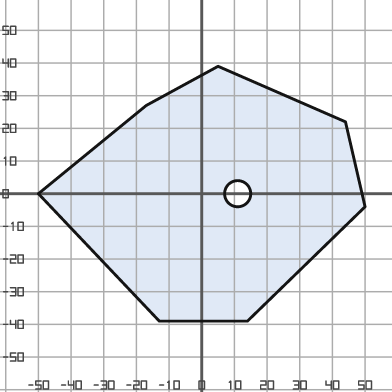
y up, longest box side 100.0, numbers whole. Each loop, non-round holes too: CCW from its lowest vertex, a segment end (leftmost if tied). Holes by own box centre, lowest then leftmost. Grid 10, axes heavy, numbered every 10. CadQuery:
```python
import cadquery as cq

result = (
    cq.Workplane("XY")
    .moveTo(-13.0, -39.0)
    .lineTo(14.0, -39.0)
    .lineTo(50.0, -4.0)
    .lineTo(44.0, 22.0)
    .lineTo(5.0, 39.0)
    .lineTo(-17.0, 27.0)
    .lineTo(-50.0, 0.0)
    .close()
    .moveTo(11.0, 0.0)
    .circle(4.0)
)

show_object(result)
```